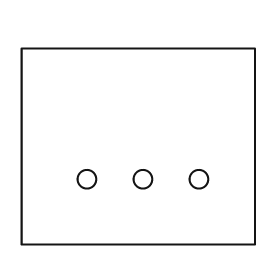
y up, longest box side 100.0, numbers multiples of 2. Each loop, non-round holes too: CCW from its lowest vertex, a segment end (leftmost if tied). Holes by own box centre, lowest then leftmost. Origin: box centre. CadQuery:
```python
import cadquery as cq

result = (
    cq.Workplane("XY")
    .moveTo(-50.0, -42.0)
    .lineTo(50.0, -42.0)
    .lineTo(50.0, 42.0)
    .lineTo(-50.0, 42.0)
    .close()
    .moveTo(-22.0, -14.0)
    .circle(4.0)
    .moveTo(2.0, -14.0)
    .circle(4.0)
    .moveTo(26.0, -14.0)
    .circle(4.0)
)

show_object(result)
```